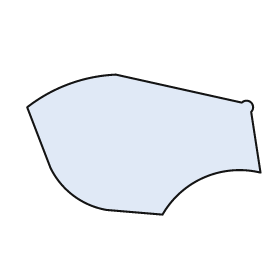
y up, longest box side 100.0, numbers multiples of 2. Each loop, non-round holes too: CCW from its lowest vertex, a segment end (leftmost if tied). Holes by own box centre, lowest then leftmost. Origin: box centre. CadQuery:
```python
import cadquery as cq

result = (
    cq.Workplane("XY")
    .moveTo(8.0, -30.0)
    .threePointArc((26.0, -14.0), (50.0, -12.0))
    .lineTo(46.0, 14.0)
    .threePointArc((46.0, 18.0), (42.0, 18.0))
    .lineTo(-12.0, 30.0)
    .threePointArc((-32.0, 26.0), (-50.0, 16.0))
    .lineTo(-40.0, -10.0)
    .threePointArc((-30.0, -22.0), (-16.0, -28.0))
    .close()
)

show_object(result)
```